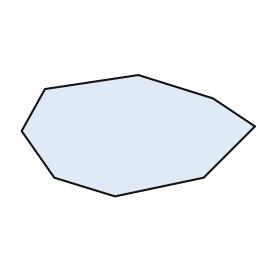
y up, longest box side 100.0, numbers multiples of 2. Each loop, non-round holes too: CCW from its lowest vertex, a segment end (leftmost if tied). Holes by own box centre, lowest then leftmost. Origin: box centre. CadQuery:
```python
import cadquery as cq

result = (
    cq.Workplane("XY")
    .moveTo(-10.0, -26.0)
    .lineTo(28.0, -18.0)
    .lineTo(50.0, 4.0)
    .lineTo(32.0, 16.0)
    .lineTo(0.0, 26.0)
    .lineTo(-40.0, 20.0)
    .lineTo(-50.0, 2.0)
    .lineTo(-36.0, -18.0)
    .close()
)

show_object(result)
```